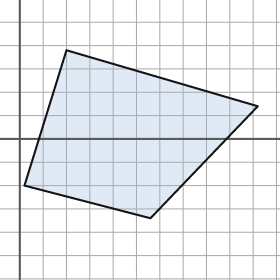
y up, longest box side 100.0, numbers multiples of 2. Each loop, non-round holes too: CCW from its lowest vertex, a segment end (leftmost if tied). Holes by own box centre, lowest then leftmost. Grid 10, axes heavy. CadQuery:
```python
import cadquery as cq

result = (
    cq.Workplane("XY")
    .moveTo(56.0, -34.0)
    .lineTo(102.0, 14.0)
    .lineTo(20.0, 38.0)
    .lineTo(2.0, -20.0)
    .close()
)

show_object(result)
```